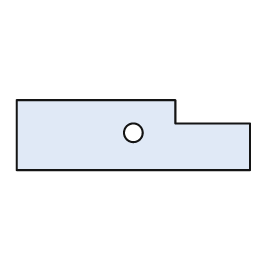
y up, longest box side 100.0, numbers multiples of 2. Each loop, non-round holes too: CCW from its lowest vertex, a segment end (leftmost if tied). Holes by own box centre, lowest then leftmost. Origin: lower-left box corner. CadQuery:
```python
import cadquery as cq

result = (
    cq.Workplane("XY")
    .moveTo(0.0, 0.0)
    .lineTo(100.0, 0.0)
    .lineTo(100.0, 20.0)
    .lineTo(68.0, 20.0)
    .lineTo(68.0, 30.0)
    .lineTo(0.0, 30.0)
    .close()
    .moveTo(50.0, 16.0)
    .circle(4.0)
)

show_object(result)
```